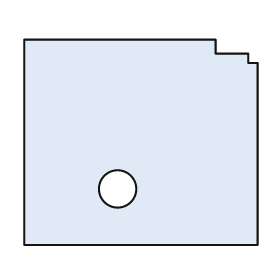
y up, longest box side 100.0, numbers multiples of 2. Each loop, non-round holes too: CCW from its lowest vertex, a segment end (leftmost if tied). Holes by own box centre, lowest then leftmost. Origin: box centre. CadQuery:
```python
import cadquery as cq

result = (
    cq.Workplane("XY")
    .moveTo(-50.0, -44.0)
    .lineTo(50.0, -44.0)
    .lineTo(50.0, 34.0)
    .lineTo(46.0, 34.0)
    .lineTo(46.0, 38.0)
    .lineTo(32.0, 38.0)
    .lineTo(32.0, 44.0)
    .lineTo(-50.0, 44.0)
    .close()
    .moveTo(-10.0, -20.0)
    .circle(8.0)
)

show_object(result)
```